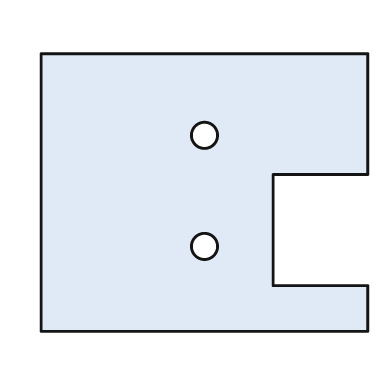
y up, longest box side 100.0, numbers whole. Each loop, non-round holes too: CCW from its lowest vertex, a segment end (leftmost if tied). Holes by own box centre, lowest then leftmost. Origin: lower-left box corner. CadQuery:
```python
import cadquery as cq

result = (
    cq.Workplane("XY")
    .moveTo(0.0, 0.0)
    .lineTo(100.0, 0.0)
    .lineTo(100.0, 14.0)
    .lineTo(71.0, 14.0)
    .lineTo(71.0, 48.0)
    .lineTo(100.0, 48.0)
    .lineTo(100.0, 85.0)
    .lineTo(0.0, 85.0)
    .close()
    .moveTo(50.0, 26.0)
    .circle(4.0)
    .moveTo(50.0, 60.0)
    .circle(4.0)
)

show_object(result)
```